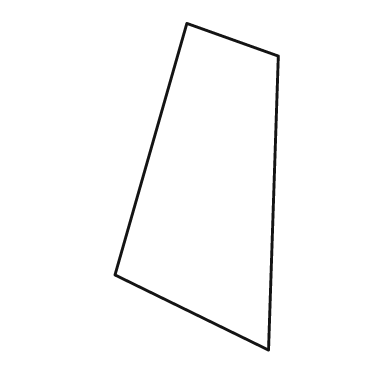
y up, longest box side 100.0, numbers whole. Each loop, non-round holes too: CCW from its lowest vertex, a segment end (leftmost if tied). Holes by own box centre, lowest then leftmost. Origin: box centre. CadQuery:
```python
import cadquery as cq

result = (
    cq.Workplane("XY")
    .moveTo(22.0, -50.0)
    .lineTo(25.0, 40.0)
    .lineTo(-3.0, 50.0)
    .lineTo(-25.0, -27.0)
    .close()
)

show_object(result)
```